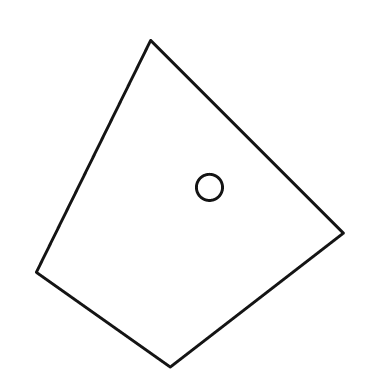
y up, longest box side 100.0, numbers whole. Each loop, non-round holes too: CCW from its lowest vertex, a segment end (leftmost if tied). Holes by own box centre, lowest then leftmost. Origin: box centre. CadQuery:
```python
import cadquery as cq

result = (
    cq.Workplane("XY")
    .moveTo(-6.0, -50.0)
    .lineTo(47.0, -9.0)
    .lineTo(-12.0, 50.0)
    .lineTo(-47.0, -21.0)
    .close()
    .moveTo(6.0, 5.0)
    .circle(4.0)
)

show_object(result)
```